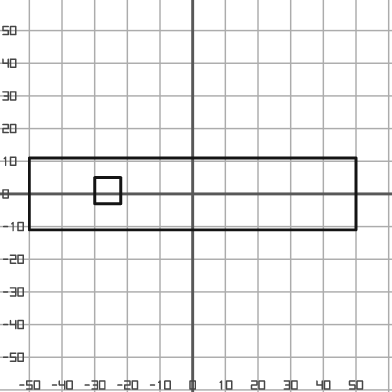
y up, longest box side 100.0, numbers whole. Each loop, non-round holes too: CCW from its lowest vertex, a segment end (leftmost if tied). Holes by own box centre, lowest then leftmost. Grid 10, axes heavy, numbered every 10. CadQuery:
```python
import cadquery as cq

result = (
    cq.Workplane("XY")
    .moveTo(-50.0, -11.0)
    .lineTo(50.0, -11.0)
    .lineTo(50.0, 11.0)
    .lineTo(-50.0, 11.0)
    .close()
    .moveTo(-30.0, -3.0)
    .lineTo(-22.0, -3.0)
    .lineTo(-22.0, 5.0)
    .lineTo(-30.0, 5.0)
    .close()
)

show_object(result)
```